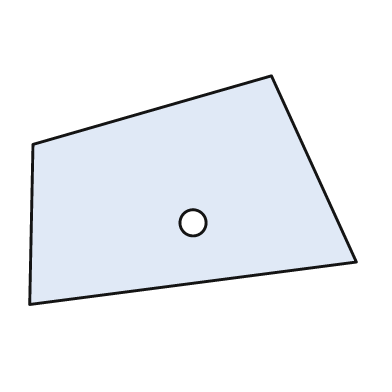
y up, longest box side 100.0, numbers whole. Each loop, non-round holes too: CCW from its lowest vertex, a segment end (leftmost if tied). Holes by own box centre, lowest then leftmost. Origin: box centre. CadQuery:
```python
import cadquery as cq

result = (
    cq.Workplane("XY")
    .moveTo(-50.0, -35.0)
    .lineTo(50.0, -22.0)
    .lineTo(24.0, 35.0)
    .lineTo(-49.0, 14.0)
    .close()
    .moveTo(0.0, -10.0)
    .circle(4.0)
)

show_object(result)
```